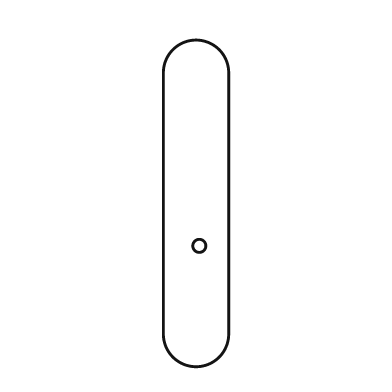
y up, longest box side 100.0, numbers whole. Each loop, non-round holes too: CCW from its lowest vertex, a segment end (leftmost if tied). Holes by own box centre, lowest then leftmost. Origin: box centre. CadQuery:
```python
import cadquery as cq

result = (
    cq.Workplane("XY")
    .moveTo(-10.0, -40.0)
    .threePointArc((0.0, -50.0), (10.0, -40.0))
    .lineTo(10.0, 40.0)
    .threePointArc((0.0, 50.0), (-10.0, 40.0))
    .close()
    .moveTo(1.0, -13.0)
    .circle(2.0)
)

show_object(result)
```